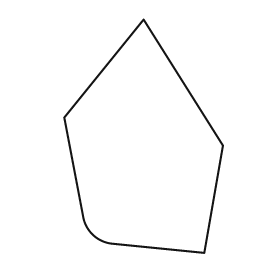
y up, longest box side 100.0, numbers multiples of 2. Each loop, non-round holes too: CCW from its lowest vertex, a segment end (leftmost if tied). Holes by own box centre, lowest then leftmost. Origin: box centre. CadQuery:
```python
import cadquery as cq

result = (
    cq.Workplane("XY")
    .moveTo(26.0, -50.0)
    .lineTo(34.0, -4.0)
    .lineTo(0.0, 50.0)
    .lineTo(-34.0, 8.0)
    .lineTo(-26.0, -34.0)
    .threePointArc((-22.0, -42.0), (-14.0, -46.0))
    .close()
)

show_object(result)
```